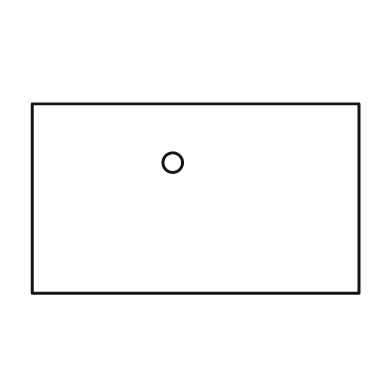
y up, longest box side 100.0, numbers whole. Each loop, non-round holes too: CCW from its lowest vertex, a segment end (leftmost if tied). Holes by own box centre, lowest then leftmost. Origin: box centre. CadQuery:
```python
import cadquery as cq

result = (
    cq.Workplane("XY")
    .moveTo(-50.0, -29.0)
    .lineTo(50.0, -29.0)
    .lineTo(50.0, 29.0)
    .lineTo(-50.0, 29.0)
    .close()
    .moveTo(-7.0, 11.0)
    .circle(3.0)
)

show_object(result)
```